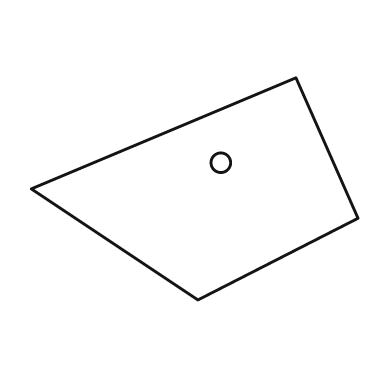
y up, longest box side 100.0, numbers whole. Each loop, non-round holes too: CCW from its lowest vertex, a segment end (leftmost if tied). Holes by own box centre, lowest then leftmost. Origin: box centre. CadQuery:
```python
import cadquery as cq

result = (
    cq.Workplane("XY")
    .moveTo(1.0, -34.0)
    .lineTo(50.0, -9.0)
    .lineTo(31.0, 34.0)
    .lineTo(-50.0, 0.0)
    .close()
    .moveTo(8.0, 8.0)
    .circle(3.0)
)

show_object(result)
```